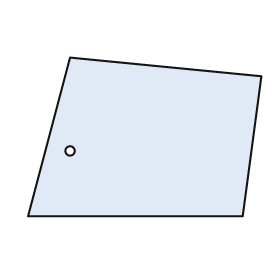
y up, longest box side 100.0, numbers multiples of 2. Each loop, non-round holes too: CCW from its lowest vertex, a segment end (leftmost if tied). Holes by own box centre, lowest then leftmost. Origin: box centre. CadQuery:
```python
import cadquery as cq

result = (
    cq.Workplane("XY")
    .moveTo(-50.0, -34.0)
    .lineTo(42.0, -34.0)
    .lineTo(50.0, 26.0)
    .lineTo(-32.0, 34.0)
    .close()
    .moveTo(-32.0, -6.0)
    .circle(2.0)
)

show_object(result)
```